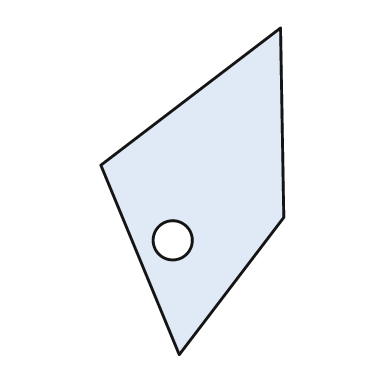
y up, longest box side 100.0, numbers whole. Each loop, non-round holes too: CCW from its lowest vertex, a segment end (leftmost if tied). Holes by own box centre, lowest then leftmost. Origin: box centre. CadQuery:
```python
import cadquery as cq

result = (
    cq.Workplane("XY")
    .moveTo(-4.0, -50.0)
    .lineTo(28.0, -8.0)
    .lineTo(27.0, 50.0)
    .lineTo(-28.0, 8.0)
    .close()
    .moveTo(-6.0, -15.0)
    .circle(6.0)
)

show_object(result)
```